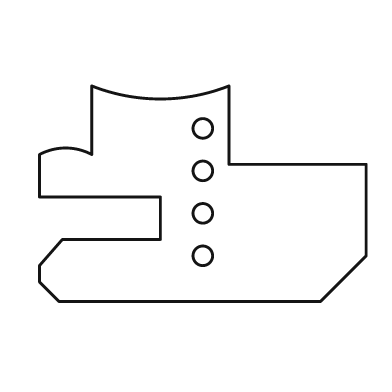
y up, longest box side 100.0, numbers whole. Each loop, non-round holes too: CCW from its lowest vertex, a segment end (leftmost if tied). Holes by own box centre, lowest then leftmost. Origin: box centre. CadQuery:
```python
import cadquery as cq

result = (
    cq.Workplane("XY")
    .moveTo(-44.0, -33.0)
    .lineTo(36.0, -33.0)
    .lineTo(50.0, -19.0)
    .lineTo(50.0, 9.0)
    .lineTo(8.0, 9.0)
    .lineTo(8.0, 33.0)
    .threePointArc((-13.0, 29.0), (-34.0, 33.0))
    .lineTo(-34.0, 12.0)
    .threePointArc((-42.0, 14.0), (-50.0, 12.0))
    .lineTo(-50.0, -1.0)
    .lineTo(-13.0, -1.0)
    .lineTo(-13.0, -14.0)
    .lineTo(-43.0, -14.0)
    .lineTo(-50.0, -22.0)
    .lineTo(-50.0, -27.0)
    .close()
    .moveTo(0.0, -19.0)
    .circle(3.0)
    .moveTo(0.0, -6.0)
    .circle(3.0)
    .moveTo(0.0, 7.0)
    .circle(3.0)
    .moveTo(0.0, 20.0)
    .circle(3.0)
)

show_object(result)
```